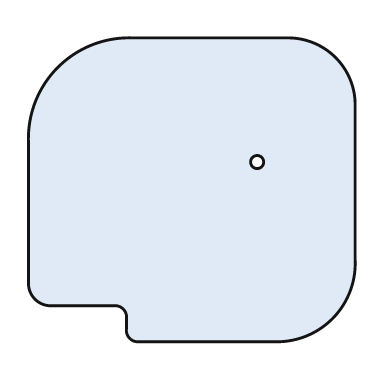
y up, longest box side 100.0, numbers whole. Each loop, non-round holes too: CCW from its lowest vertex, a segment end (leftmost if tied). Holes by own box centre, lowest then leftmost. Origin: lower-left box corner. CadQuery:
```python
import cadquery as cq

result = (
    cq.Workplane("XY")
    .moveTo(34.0, 0.0)
    .lineTo(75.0, 0.0)
    .threePointArc((93.0, 7.0), (100.0, 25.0))
    .lineTo(100.0, 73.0)
    .threePointArc((94.0, 87.0), (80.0, 93.0))
    .lineTo(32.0, 93.0)
    .threePointArc((9.0, 84.0), (0.0, 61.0))
    .lineTo(0.0, 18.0)
    .threePointArc((2.0, 13.0), (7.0, 11.0))
    .lineTo(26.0, 11.0)
    .threePointArc((29.0, 10.0), (30.0, 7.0))
    .lineTo(30.0, 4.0)
    .threePointArc((31.0, 1.0), (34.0, 0.0))
    .close()
    .moveTo(70.0, 55.0)
    .circle(2.0)
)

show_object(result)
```